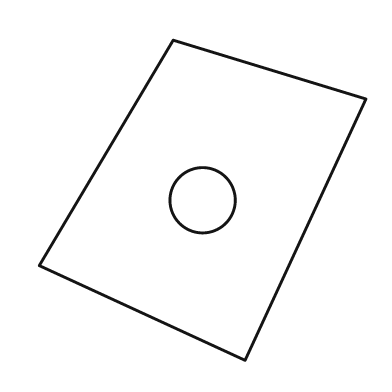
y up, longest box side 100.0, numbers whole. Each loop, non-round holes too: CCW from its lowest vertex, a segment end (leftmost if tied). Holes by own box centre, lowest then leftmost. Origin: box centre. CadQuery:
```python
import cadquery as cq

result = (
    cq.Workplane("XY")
    .moveTo(13.0, -49.0)
    .lineTo(50.0, 31.0)
    .lineTo(-9.0, 49.0)
    .lineTo(-50.0, -20.0)
    .close()
    .moveTo(0.0, 0.0)
    .circle(10.0)
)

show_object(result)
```